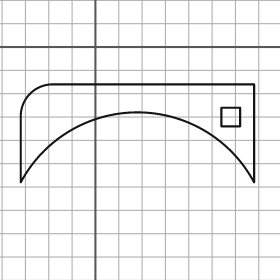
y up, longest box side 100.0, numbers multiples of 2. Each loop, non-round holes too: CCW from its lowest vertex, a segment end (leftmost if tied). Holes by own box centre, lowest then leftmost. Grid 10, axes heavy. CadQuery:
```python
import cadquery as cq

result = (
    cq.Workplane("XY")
    .moveTo(-32.0, -58.0)
    .threePointArc((18.0, -28.0), (68.0, -58.0))
    .lineTo(68.0, -16.0)
    .lineTo(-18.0, -16.0)
    .threePointArc((-28.0, -20.0), (-32.0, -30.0))
    .close()
    .moveTo(54.0, -34.0)
    .lineTo(62.0, -34.0)
    .lineTo(62.0, -26.0)
    .lineTo(54.0, -26.0)
    .close()
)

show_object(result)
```